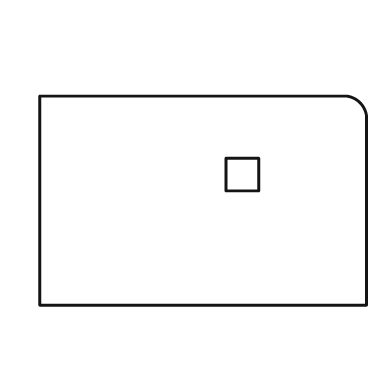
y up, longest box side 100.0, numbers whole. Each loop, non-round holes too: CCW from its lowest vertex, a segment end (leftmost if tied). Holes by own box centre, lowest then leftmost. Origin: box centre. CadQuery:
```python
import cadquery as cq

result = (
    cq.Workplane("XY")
    .moveTo(-50.0, -32.0)
    .lineTo(50.0, -32.0)
    .lineTo(50.0, 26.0)
    .threePointArc((48.0, 30.0), (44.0, 32.0))
    .lineTo(-50.0, 32.0)
    .close()
    .moveTo(7.0, 3.0)
    .lineTo(17.0, 3.0)
    .lineTo(17.0, 13.0)
    .lineTo(7.0, 13.0)
    .close()
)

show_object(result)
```